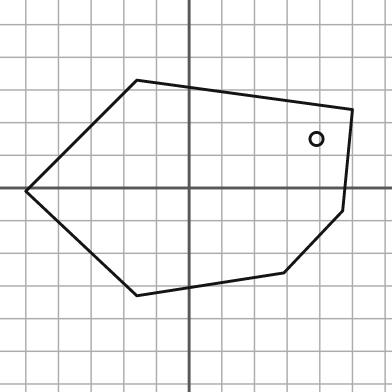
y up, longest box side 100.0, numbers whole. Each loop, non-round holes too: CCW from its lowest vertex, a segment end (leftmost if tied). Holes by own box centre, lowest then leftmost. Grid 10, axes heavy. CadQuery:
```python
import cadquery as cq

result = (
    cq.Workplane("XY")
    .moveTo(-16.0, -33.0)
    .lineTo(29.0, -26.0)
    .lineTo(47.0, -7.0)
    .lineTo(50.0, 24.0)
    .lineTo(-16.0, 33.0)
    .lineTo(-50.0, -1.0)
    .close()
    .moveTo(39.0, 15.0)
    .circle(2.0)
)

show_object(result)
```